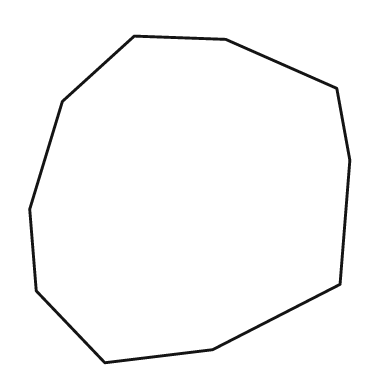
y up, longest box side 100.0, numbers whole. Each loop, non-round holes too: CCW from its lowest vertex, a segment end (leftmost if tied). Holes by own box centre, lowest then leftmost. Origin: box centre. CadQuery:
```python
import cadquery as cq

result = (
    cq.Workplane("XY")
    .moveTo(-26.0, -50.0)
    .lineTo(7.0, -46.0)
    .lineTo(46.0, -26.0)
    .lineTo(49.0, 12.0)
    .lineTo(45.0, 34.0)
    .lineTo(11.0, 49.0)
    .lineTo(-17.0, 50.0)
    .lineTo(-39.0, 30.0)
    .lineTo(-49.0, -3.0)
    .lineTo(-47.0, -28.0)
    .close()
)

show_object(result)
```